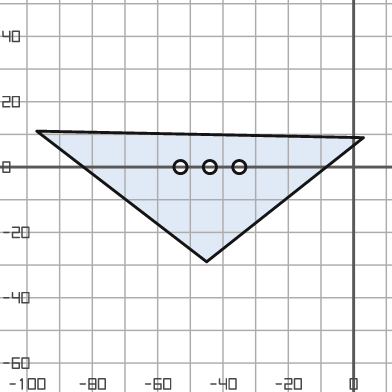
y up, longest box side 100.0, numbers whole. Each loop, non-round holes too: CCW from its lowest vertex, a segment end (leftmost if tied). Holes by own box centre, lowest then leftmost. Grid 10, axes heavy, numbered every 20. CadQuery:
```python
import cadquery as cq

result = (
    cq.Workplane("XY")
    .moveTo(-45.0, -29.0)
    .lineTo(3.0, 9.0)
    .lineTo(-97.0, 11.0)
    .close()
    .moveTo(-53.0, 0.0)
    .circle(2.0)
    .moveTo(-44.0, 0.0)
    .circle(2.0)
    .moveTo(-35.0, 0.0)
    .circle(2.0)
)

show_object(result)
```